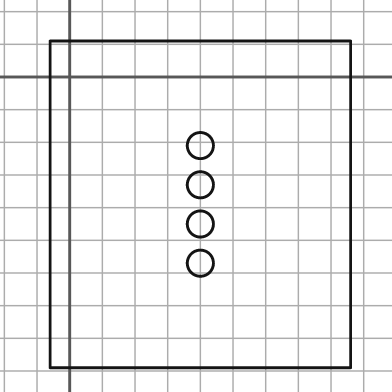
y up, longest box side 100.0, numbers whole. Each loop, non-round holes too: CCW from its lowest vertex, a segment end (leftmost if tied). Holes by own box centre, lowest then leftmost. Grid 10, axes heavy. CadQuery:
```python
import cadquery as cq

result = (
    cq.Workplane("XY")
    .moveTo(-6.0, -89.0)
    .lineTo(86.0, -89.0)
    .lineTo(86.0, 11.0)
    .lineTo(-6.0, 11.0)
    .close()
    .moveTo(40.0, -57.0)
    .circle(4.0)
    .moveTo(40.0, -45.0)
    .circle(4.0)
    .moveTo(40.0, -33.0)
    .circle(4.0)
    .moveTo(40.0, -21.0)
    .circle(4.0)
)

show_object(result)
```